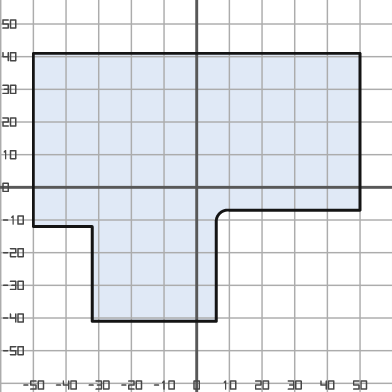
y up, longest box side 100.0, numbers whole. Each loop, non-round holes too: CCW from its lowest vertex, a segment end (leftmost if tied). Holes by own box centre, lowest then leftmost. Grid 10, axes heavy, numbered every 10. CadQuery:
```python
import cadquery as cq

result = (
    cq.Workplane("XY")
    .moveTo(-32.0, -41.0)
    .lineTo(6.0, -41.0)
    .lineTo(6.0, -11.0)
    .threePointArc((7.0, -8.0), (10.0, -7.0))
    .lineTo(50.0, -7.0)
    .lineTo(50.0, 41.0)
    .lineTo(-50.0, 41.0)
    .lineTo(-50.0, -12.0)
    .lineTo(-32.0, -12.0)
    .close()
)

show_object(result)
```